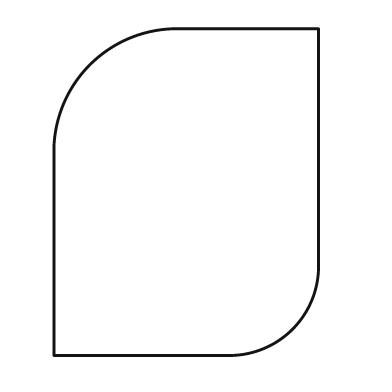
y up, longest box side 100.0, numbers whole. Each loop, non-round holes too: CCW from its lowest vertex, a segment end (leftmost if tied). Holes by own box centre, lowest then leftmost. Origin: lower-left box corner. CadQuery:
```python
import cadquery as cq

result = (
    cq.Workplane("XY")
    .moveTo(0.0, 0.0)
    .lineTo(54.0, 0.0)
    .threePointArc((73.0, 8.0), (81.0, 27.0))
    .lineTo(81.0, 100.0)
    .lineTo(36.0, 100.0)
    .threePointArc((11.0, 89.0), (0.0, 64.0))
    .close()
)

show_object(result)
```